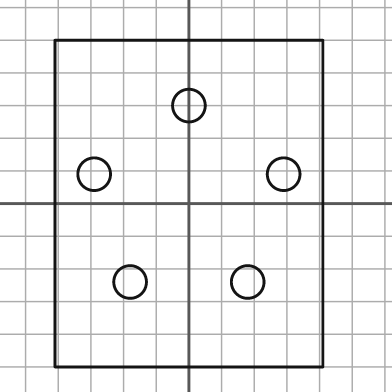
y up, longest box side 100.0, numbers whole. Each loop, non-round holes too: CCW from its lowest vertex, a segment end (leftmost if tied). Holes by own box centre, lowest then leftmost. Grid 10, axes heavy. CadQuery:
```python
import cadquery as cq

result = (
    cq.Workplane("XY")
    .moveTo(-41.0, -50.0)
    .lineTo(41.0, -50.0)
    .lineTo(41.0, 50.0)
    .lineTo(-41.0, 50.0)
    .close()
    .moveTo(-18.0, -24.0)
    .circle(5.0)
    .moveTo(18.0, -24.0)
    .circle(5.0)
    .moveTo(-29.0, 9.0)
    .circle(5.0)
    .moveTo(29.0, 9.0)
    .circle(5.0)
    .moveTo(0.0, 30.0)
    .circle(5.0)
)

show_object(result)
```